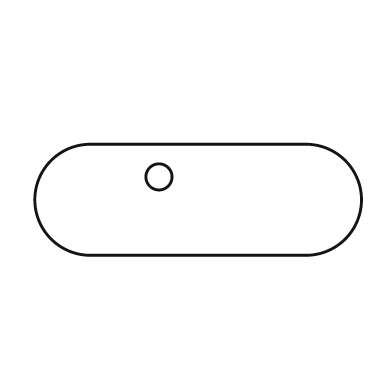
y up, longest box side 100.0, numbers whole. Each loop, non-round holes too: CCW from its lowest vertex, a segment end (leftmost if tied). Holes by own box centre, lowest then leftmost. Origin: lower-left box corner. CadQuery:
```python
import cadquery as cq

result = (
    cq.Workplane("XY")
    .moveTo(17.0, 0.0)
    .lineTo(83.0, 0.0)
    .threePointArc((100.0, 17.0), (83.0, 34.0))
    .lineTo(17.0, 34.0)
    .threePointArc((0.0, 17.0), (17.0, 0.0))
    .close()
    .moveTo(38.0, 24.0)
    .circle(4.0)
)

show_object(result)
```